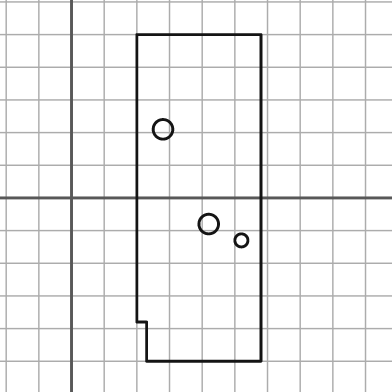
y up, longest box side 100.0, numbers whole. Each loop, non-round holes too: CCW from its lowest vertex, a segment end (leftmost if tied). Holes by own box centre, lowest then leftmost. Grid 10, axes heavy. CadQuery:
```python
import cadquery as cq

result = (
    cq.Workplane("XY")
    .moveTo(23.0, -50.0)
    .lineTo(58.0, -50.0)
    .lineTo(58.0, 50.0)
    .lineTo(20.0, 50.0)
    .lineTo(20.0, -38.0)
    .lineTo(23.0, -38.0)
    .close()
    .moveTo(52.0, -13.0)
    .circle(2.0)
    .moveTo(42.0, -8.0)
    .circle(3.0)
    .moveTo(28.0, 21.0)
    .circle(3.0)
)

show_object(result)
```